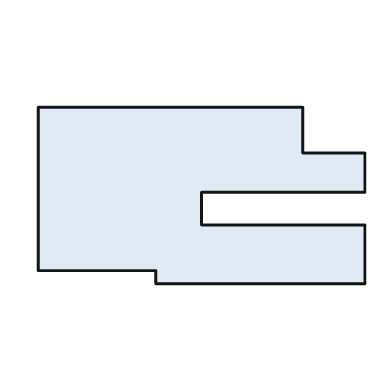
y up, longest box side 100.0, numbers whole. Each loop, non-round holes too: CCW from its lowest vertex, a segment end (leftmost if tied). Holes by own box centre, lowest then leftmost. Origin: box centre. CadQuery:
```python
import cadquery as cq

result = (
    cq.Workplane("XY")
    .moveTo(-14.0, -27.0)
    .lineTo(50.0, -27.0)
    .lineTo(50.0, -9.0)
    .lineTo(0.0, -9.0)
    .lineTo(0.0, 1.0)
    .lineTo(50.0, 1.0)
    .lineTo(50.0, 13.0)
    .lineTo(31.0, 13.0)
    .lineTo(31.0, 27.0)
    .lineTo(-50.0, 27.0)
    .lineTo(-50.0, -23.0)
    .lineTo(-14.0, -23.0)
    .close()
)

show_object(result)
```